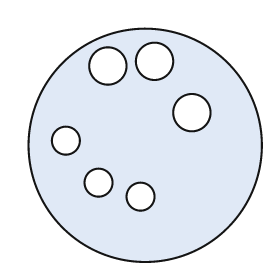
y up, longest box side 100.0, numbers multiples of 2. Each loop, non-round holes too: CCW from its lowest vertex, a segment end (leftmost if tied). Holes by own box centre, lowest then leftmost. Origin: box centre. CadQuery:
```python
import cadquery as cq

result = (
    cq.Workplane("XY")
    .moveTo(0.0, 0.0)
    .circle(50.0)
    .moveTo(-2.0, -22.0)
    .circle(6.0)
    .moveTo(-20.0, -16.0)
    .circle(6.0)
    .moveTo(-34.0, 2.0)
    .circle(6.0)
    .moveTo(20.0, 14.0)
    .circle(8.0)
    .moveTo(-16.0, 34.0)
    .circle(8.0)
    .moveTo(4.0, 36.0)
    .circle(8.0)
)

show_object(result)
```